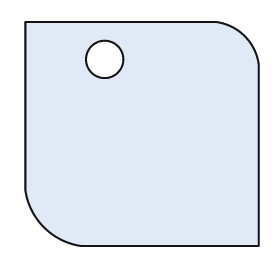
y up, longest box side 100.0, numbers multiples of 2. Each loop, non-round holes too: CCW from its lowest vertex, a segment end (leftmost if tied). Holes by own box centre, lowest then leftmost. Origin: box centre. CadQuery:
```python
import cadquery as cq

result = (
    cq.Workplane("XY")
    .moveTo(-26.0, -48.0)
    .lineTo(50.0, -48.0)
    .lineTo(50.0, 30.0)
    .threePointArc((44.0, 42.0), (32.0, 48.0))
    .lineTo(-50.0, 48.0)
    .lineTo(-50.0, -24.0)
    .threePointArc((-42.0, -40.0), (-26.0, -48.0))
    .close()
    .moveTo(-16.0, 32.0)
    .circle(8.0)
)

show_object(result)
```